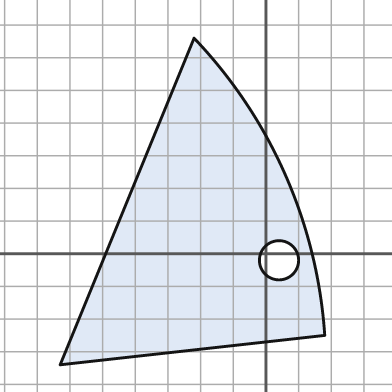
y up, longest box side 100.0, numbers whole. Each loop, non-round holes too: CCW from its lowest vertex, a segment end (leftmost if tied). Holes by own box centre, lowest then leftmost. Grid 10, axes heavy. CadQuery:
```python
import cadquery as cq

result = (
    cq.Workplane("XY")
    .moveTo(-63.0, -34.0)
    .lineTo(18.0, -25.0)
    .threePointArc((6.0, 24.0), (-22.0, 66.0))
    .close()
    .moveTo(4.0, -2.0)
    .circle(6.0)
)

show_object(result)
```